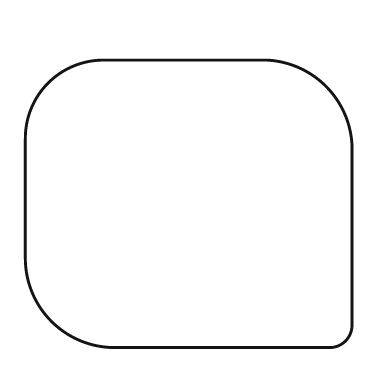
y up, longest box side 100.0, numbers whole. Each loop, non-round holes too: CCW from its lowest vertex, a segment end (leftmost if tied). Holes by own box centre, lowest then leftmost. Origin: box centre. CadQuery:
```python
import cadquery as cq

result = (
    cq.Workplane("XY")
    .moveTo(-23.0, -44.0)
    .lineTo(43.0, -44.0)
    .threePointArc((48.0, -42.0), (50.0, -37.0))
    .lineTo(50.0, 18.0)
    .threePointArc((42.0, 36.0), (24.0, 44.0))
    .lineTo(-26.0, 44.0)
    .threePointArc((-43.0, 37.0), (-50.0, 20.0))
    .lineTo(-50.0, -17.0)
    .threePointArc((-42.0, -36.0), (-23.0, -44.0))
    .close()
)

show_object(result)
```